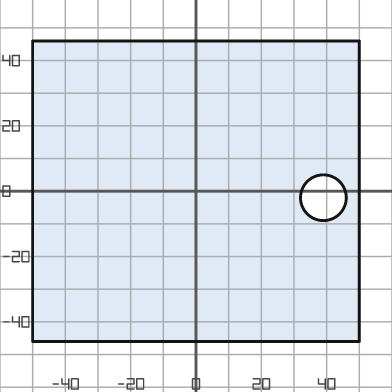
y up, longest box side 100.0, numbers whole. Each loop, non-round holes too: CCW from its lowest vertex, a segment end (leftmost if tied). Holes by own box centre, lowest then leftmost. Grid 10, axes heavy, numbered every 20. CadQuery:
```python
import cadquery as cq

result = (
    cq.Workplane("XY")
    .moveTo(-50.0, -46.0)
    .lineTo(50.0, -46.0)
    .lineTo(50.0, 46.0)
    .lineTo(-50.0, 46.0)
    .close()
    .moveTo(39.0, -2.0)
    .circle(7.0)
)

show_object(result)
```